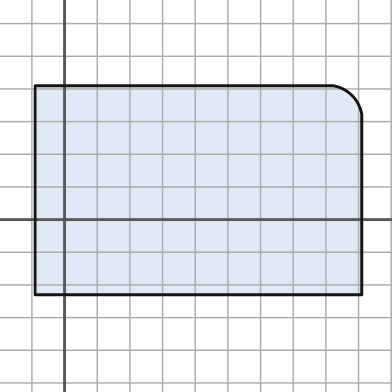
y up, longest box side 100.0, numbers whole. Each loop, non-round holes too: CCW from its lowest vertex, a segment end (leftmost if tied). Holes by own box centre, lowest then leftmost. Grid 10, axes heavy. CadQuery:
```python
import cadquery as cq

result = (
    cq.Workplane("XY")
    .moveTo(-9.0, -23.0)
    .lineTo(91.0, -23.0)
    .lineTo(91.0, 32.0)
    .threePointArc((88.0, 38.0), (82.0, 41.0))
    .lineTo(-9.0, 41.0)
    .close()
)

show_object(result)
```